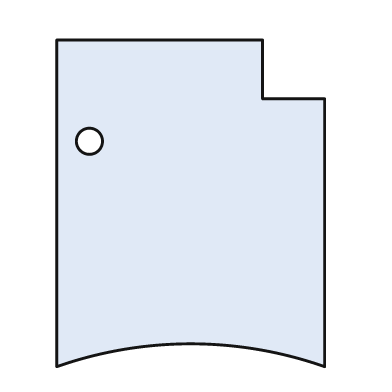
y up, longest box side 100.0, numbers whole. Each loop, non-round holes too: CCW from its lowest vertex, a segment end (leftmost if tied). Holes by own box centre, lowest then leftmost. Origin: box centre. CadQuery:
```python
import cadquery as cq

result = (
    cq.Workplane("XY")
    .moveTo(-41.0, -50.0)
    .threePointArc((0.0, -43.0), (41.0, -50.0))
    .lineTo(41.0, 32.0)
    .lineTo(22.0, 32.0)
    .lineTo(22.0, 50.0)
    .lineTo(-41.0, 50.0)
    .close()
    .moveTo(-31.0, 19.0)
    .circle(4.0)
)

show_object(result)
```